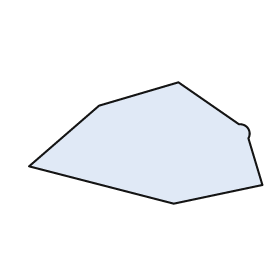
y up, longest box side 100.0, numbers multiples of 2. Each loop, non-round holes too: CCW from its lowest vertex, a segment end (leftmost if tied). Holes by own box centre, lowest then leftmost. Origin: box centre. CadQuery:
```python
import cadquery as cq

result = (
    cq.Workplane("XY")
    .moveTo(12.0, -26.0)
    .lineTo(50.0, -18.0)
    .lineTo(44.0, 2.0)
    .threePointArc((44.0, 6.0), (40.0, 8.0))
    .lineTo(14.0, 26.0)
    .lineTo(-20.0, 16.0)
    .lineTo(-50.0, -10.0)
    .close()
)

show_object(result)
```